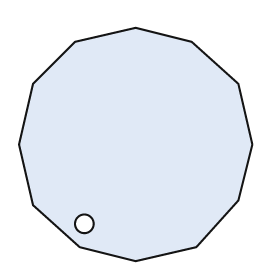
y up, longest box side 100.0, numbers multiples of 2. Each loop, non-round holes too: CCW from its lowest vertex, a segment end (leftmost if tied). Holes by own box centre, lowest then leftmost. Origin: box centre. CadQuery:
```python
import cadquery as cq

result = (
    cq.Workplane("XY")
    .moveTo(0.0, -50.0)
    .lineTo(26.0, -44.0)
    .lineTo(44.0, -24.0)
    .lineTo(50.0, 0.0)
    .lineTo(44.0, 26.0)
    .lineTo(24.0, 44.0)
    .lineTo(0.0, 50.0)
    .lineTo(-26.0, 44.0)
    .lineTo(-44.0, 26.0)
    .lineTo(-50.0, 0.0)
    .lineTo(-44.0, -26.0)
    .lineTo(-24.0, -44.0)
    .close()
    .moveTo(-22.0, -34.0)
    .circle(4.0)
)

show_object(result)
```